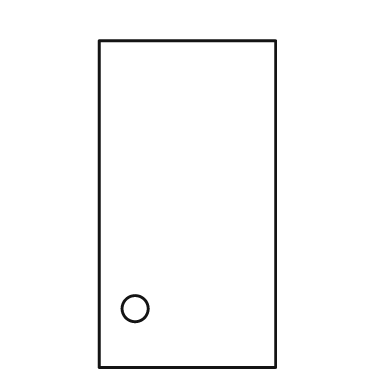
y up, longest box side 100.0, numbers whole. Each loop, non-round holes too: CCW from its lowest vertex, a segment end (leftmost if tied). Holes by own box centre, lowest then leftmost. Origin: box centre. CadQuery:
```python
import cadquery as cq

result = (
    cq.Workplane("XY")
    .moveTo(-27.0, -50.0)
    .lineTo(27.0, -50.0)
    .lineTo(27.0, 50.0)
    .lineTo(-27.0, 50.0)
    .close()
    .moveTo(-16.0, -32.0)
    .circle(4.0)
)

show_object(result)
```